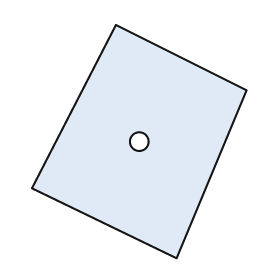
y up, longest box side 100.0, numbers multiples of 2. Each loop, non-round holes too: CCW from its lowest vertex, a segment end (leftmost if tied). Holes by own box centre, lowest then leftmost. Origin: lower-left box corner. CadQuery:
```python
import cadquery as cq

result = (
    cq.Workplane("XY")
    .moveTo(62.0, 0.0)
    .lineTo(92.0, 72.0)
    .lineTo(36.0, 100.0)
    .lineTo(0.0, 30.0)
    .close()
    .moveTo(46.0, 50.0)
    .circle(4.0)
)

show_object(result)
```